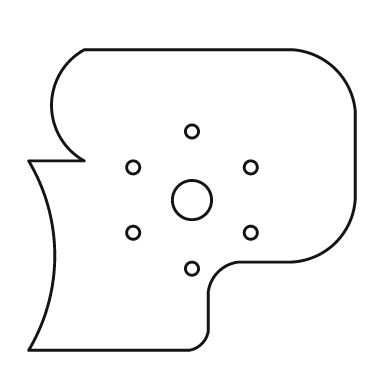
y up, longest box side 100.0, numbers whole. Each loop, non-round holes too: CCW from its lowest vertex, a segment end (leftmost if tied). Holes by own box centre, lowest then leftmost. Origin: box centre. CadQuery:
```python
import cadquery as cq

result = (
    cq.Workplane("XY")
    .moveTo(-50.0, -46.0)
    .lineTo(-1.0, -46.0)
    .threePointArc((3.0, -44.0), (5.0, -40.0))
    .lineTo(5.0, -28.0)
    .threePointArc((8.0, -22.0), (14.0, -19.0))
    .lineTo(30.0, -19.0)
    .threePointArc((44.0, -13.0), (50.0, 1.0))
    .lineTo(50.0, 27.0)
    .threePointArc((44.0, 40.0), (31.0, 46.0))
    .lineTo(-33.0, 46.0)
    .threePointArc((-43.0, 29.0), (-33.0, 12.0))
    .lineTo(-50.0, 12.0)
    .threePointArc((-42.0, -17.0), (-50.0, -46.0))
    .close()
    .moveTo(0.0, -21.0)
    .circle(2.0)
    .moveTo(-18.0, -10.0)
    .circle(2.0)
    .moveTo(18.0, -10.0)
    .circle(2.0)
    .moveTo(0.0, 0.0)
    .circle(6.0)
    .moveTo(-18.0, 10.0)
    .circle(2.0)
    .moveTo(18.0, 10.0)
    .circle(2.0)
    .moveTo(0.0, 21.0)
    .circle(2.0)
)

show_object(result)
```